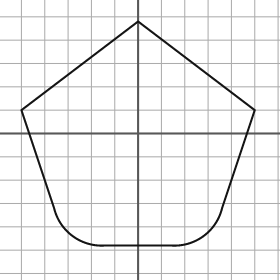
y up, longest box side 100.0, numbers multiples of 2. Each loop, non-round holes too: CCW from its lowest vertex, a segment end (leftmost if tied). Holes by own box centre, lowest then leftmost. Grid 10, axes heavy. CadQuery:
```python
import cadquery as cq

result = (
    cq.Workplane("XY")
    .moveTo(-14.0, -48.0)
    .lineTo(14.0, -48.0)
    .threePointArc((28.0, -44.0), (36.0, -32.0))
    .lineTo(50.0, 10.0)
    .lineTo(0.0, 48.0)
    .lineTo(-50.0, 10.0)
    .lineTo(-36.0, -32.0)
    .threePointArc((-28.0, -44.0), (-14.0, -48.0))
    .close()
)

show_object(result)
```